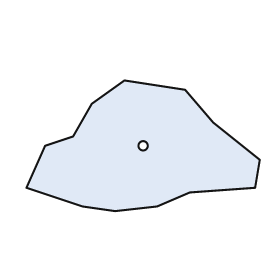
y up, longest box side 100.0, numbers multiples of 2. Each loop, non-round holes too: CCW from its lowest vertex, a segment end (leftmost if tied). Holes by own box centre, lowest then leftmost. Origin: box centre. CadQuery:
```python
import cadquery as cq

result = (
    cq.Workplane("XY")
    .moveTo(-12.0, -28.0)
    .lineTo(6.0, -26.0)
    .lineTo(20.0, -20.0)
    .lineTo(48.0, -18.0)
    .lineTo(50.0, -6.0)
    .lineTo(30.0, 10.0)
    .lineTo(18.0, 24.0)
    .lineTo(-8.0, 28.0)
    .lineTo(-22.0, 18.0)
    .lineTo(-30.0, 4.0)
    .lineTo(-42.0, 0.0)
    .lineTo(-50.0, -18.0)
    .lineTo(-26.0, -26.0)
    .close()
    .moveTo(0.0, 0.0)
    .circle(2.0)
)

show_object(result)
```